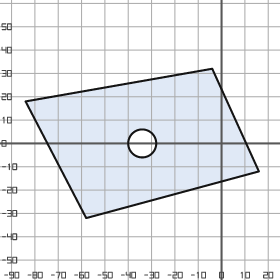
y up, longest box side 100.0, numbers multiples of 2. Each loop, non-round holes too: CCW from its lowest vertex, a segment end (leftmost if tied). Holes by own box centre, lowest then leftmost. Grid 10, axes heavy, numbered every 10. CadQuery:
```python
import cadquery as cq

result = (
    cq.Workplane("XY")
    .moveTo(-58.0, -32.0)
    .lineTo(16.0, -12.0)
    .lineTo(-4.0, 32.0)
    .lineTo(-84.0, 18.0)
    .close()
    .moveTo(-34.0, 0.0)
    .circle(6.0)
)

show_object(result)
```